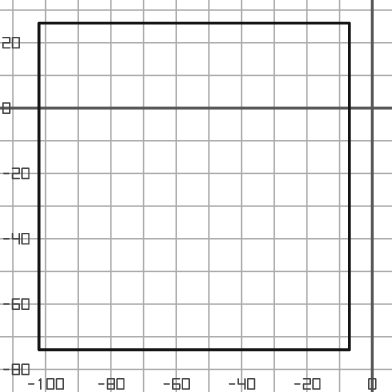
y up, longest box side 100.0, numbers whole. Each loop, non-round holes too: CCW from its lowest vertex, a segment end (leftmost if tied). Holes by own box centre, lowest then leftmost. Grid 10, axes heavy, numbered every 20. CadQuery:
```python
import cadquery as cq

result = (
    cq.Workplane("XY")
    .moveTo(-102.0, -74.0)
    .lineTo(-7.0, -74.0)
    .lineTo(-7.0, 26.0)
    .lineTo(-102.0, 26.0)
    .close()
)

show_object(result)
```